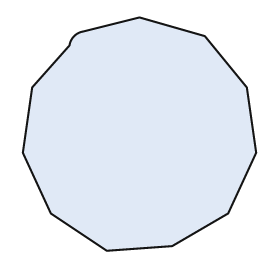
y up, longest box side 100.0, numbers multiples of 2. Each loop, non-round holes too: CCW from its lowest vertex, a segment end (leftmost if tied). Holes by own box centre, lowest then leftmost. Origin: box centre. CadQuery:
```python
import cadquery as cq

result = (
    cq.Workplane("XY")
    .moveTo(-14.0, -50.0)
    .lineTo(14.0, -48.0)
    .lineTo(38.0, -34.0)
    .lineTo(50.0, -8.0)
    .lineTo(46.0, 20.0)
    .lineTo(28.0, 42.0)
    .lineTo(0.0, 50.0)
    .lineTo(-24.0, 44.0)
    .threePointArc((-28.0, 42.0), (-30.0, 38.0))
    .lineTo(-46.0, 20.0)
    .lineTo(-50.0, -8.0)
    .lineTo(-38.0, -34.0)
    .close()
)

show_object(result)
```